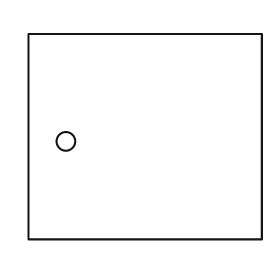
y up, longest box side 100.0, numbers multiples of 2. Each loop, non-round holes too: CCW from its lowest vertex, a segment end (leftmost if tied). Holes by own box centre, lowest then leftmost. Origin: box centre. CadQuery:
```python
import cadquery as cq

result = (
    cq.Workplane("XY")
    .moveTo(-50.0, -44.0)
    .lineTo(50.0, -44.0)
    .lineTo(50.0, 44.0)
    .lineTo(-50.0, 44.0)
    .close()
    .moveTo(-34.0, -2.0)
    .circle(4.0)
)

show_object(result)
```